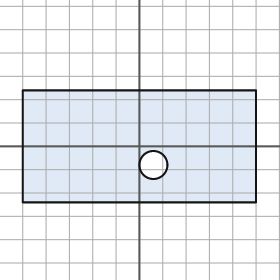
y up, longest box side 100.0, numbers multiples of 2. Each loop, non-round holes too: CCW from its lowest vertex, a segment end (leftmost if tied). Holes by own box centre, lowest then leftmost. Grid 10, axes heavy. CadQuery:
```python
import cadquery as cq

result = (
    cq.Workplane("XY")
    .moveTo(-50.0, -24.0)
    .lineTo(50.0, -24.0)
    .lineTo(50.0, 24.0)
    .lineTo(-50.0, 24.0)
    .close()
    .moveTo(6.0, -8.0)
    .circle(6.0)
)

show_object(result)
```